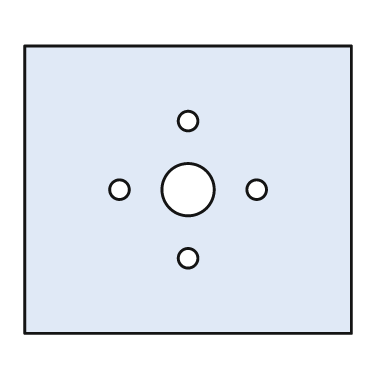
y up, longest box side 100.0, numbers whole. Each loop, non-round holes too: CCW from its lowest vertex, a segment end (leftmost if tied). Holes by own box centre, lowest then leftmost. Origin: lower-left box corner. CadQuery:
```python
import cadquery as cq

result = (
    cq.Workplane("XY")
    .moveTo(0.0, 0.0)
    .lineTo(100.0, 0.0)
    .lineTo(100.0, 88.0)
    .lineTo(0.0, 88.0)
    .close()
    .moveTo(50.0, 23.0)
    .circle(3.0)
    .moveTo(29.0, 44.0)
    .circle(3.0)
    .moveTo(50.0, 44.0)
    .circle(8.0)
    .moveTo(71.0, 44.0)
    .circle(3.0)
    .moveTo(50.0, 65.0)
    .circle(3.0)
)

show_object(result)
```